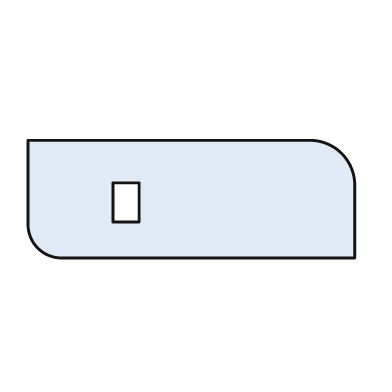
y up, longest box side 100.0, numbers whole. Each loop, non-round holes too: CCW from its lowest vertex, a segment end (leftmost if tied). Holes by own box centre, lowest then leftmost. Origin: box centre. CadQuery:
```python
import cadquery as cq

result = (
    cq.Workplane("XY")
    .moveTo(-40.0, -18.0)
    .lineTo(50.0, -18.0)
    .lineTo(50.0, 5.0)
    .threePointArc((46.0, 14.0), (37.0, 18.0))
    .lineTo(-50.0, 18.0)
    .lineTo(-50.0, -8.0)
    .threePointArc((-47.0, -15.0), (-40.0, -18.0))
    .close()
    .moveTo(-24.0, -7.0)
    .lineTo(-16.0, -7.0)
    .lineTo(-16.0, 5.0)
    .lineTo(-24.0, 5.0)
    .close()
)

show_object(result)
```